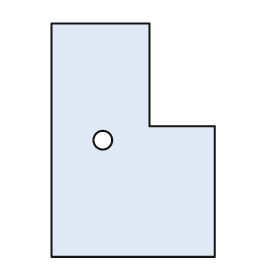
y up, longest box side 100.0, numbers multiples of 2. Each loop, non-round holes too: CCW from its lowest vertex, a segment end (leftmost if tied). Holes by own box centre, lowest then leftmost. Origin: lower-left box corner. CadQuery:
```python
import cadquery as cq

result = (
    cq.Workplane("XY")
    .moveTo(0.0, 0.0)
    .lineTo(70.0, 0.0)
    .lineTo(70.0, 56.0)
    .lineTo(42.0, 56.0)
    .lineTo(42.0, 100.0)
    .lineTo(0.0, 100.0)
    .close()
    .moveTo(22.0, 50.0)
    .circle(4.0)
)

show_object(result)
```